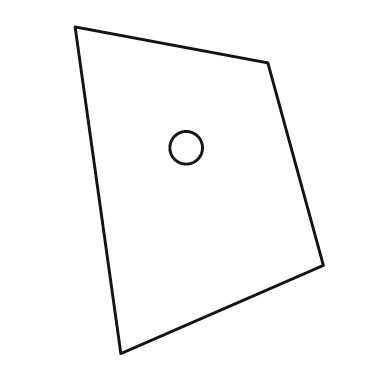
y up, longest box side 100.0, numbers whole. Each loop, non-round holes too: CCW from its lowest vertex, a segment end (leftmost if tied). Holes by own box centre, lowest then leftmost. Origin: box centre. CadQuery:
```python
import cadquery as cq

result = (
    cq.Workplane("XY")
    .moveTo(-24.0, -50.0)
    .lineTo(38.0, -23.0)
    .lineTo(21.0, 39.0)
    .lineTo(-38.0, 50.0)
    .close()
    .moveTo(-4.0, 13.0)
    .circle(5.0)
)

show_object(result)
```